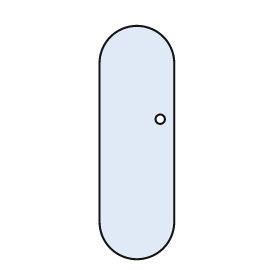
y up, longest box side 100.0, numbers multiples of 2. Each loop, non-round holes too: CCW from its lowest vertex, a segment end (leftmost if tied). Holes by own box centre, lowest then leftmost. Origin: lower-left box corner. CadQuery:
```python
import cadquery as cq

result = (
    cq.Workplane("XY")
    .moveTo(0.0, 16.0)
    .threePointArc((16.0, 0.0), (32.0, 16.0))
    .lineTo(32.0, 84.0)
    .threePointArc((16.0, 100.0), (0.0, 84.0))
    .close()
    .moveTo(26.0, 60.0)
    .circle(2.0)
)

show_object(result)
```